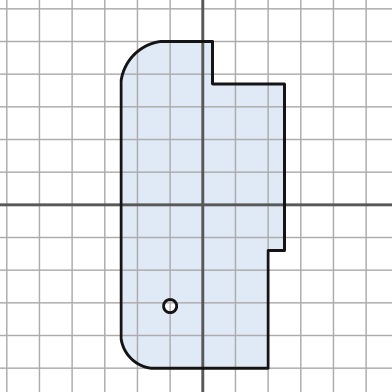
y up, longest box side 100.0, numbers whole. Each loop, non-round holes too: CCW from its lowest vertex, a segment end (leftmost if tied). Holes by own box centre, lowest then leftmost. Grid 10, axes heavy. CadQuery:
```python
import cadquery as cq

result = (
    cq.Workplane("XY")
    .moveTo(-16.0, -50.0)
    .lineTo(20.0, -50.0)
    .lineTo(20.0, -14.0)
    .lineTo(25.0, -14.0)
    .lineTo(25.0, 37.0)
    .lineTo(3.0, 37.0)
    .lineTo(3.0, 50.0)
    .lineTo(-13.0, 50.0)
    .threePointArc((-21.0, 46.0), (-25.0, 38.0))
    .lineTo(-25.0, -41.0)
    .threePointArc((-22.0, -47.0), (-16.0, -50.0))
    .close()
    .moveTo(-10.0, -31.0)
    .circle(2.0)
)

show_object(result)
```